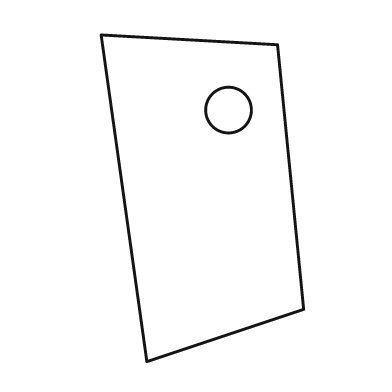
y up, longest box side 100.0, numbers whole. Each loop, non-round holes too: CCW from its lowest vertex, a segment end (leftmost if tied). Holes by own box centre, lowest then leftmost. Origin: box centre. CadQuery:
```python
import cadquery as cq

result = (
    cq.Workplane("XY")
    .moveTo(-17.0, -50.0)
    .lineTo(31.0, -34.0)
    .lineTo(23.0, 47.0)
    .lineTo(-31.0, 50.0)
    .close()
    .moveTo(8.0, 27.0)
    .circle(7.0)
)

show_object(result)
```